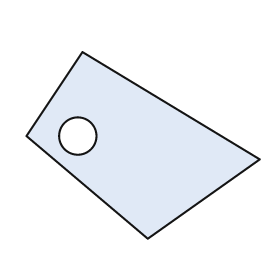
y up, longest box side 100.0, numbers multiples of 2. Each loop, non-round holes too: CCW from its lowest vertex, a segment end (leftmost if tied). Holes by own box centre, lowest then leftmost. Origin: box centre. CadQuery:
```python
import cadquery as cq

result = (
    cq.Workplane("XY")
    .moveTo(2.0, -40.0)
    .lineTo(50.0, -6.0)
    .lineTo(-26.0, 40.0)
    .lineTo(-50.0, 4.0)
    .close()
    .moveTo(-28.0, 4.0)
    .circle(8.0)
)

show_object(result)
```